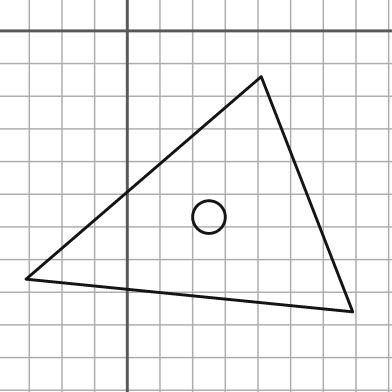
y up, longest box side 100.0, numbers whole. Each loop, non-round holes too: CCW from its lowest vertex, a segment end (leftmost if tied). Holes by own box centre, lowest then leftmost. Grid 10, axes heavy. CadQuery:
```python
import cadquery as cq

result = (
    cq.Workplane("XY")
    .moveTo(69.0, -86.0)
    .lineTo(41.0, -14.0)
    .lineTo(-31.0, -76.0)
    .close()
    .moveTo(25.0, -57.0)
    .circle(5.0)
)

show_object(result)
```